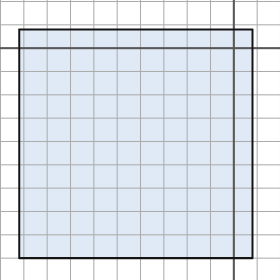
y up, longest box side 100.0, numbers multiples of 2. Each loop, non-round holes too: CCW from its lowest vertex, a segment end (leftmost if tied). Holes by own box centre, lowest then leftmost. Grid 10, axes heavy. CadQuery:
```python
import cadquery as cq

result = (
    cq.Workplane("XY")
    .moveTo(-92.0, -90.0)
    .lineTo(8.0, -90.0)
    .lineTo(8.0, 8.0)
    .lineTo(-92.0, 8.0)
    .close()
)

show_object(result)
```